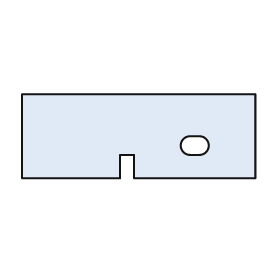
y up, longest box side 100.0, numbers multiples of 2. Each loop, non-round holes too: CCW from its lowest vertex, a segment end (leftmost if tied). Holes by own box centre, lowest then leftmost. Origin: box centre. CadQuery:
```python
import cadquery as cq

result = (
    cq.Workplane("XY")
    .moveTo(-50.0, -18.0)
    .lineTo(-8.0, -18.0)
    .lineTo(-8.0, -8.0)
    .lineTo(-2.0, -8.0)
    .lineTo(-2.0, -18.0)
    .lineTo(50.0, -18.0)
    .lineTo(50.0, 18.0)
    .lineTo(-50.0, 18.0)
    .close()
    .moveTo(22.0, -8.0)
    .lineTo(26.0, -8.0)
    .threePointArc((30.0, -4.0), (26.0, 0.0))
    .lineTo(22.0, 0.0)
    .threePointArc((18.0, -4.0), (22.0, -8.0))
    .close()
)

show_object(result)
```